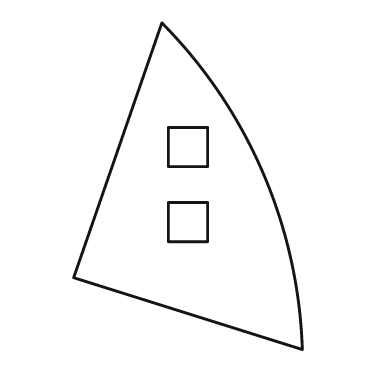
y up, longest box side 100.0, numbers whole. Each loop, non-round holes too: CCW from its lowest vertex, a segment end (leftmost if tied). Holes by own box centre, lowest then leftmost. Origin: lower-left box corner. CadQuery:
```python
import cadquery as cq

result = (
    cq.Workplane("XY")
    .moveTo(70.0, 0.0)
    .threePointArc((58.0, 54.0), (27.0, 100.0))
    .lineTo(0.0, 22.0)
    .close()
    .moveTo(29.0, 33.0)
    .lineTo(41.0, 33.0)
    .lineTo(41.0, 45.0)
    .lineTo(29.0, 45.0)
    .close()
    .moveTo(29.0, 56.0)
    .lineTo(41.0, 56.0)
    .lineTo(41.0, 68.0)
    .lineTo(29.0, 68.0)
    .close()
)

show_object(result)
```